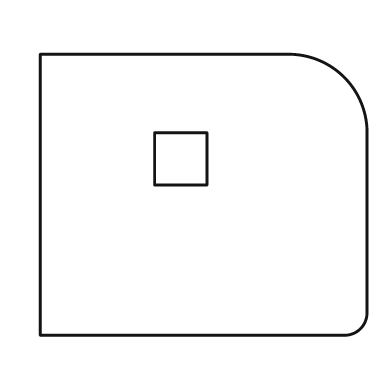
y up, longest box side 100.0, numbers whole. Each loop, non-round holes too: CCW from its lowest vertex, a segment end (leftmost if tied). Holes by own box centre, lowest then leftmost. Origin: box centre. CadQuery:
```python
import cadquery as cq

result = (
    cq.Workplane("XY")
    .moveTo(-50.0, -43.0)
    .lineTo(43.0, -43.0)
    .threePointArc((48.0, -41.0), (50.0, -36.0))
    .lineTo(50.0, 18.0)
    .threePointArc((43.0, 36.0), (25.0, 43.0))
    .lineTo(-50.0, 43.0)
    .close()
    .moveTo(-15.0, 3.0)
    .lineTo(1.0, 3.0)
    .lineTo(1.0, 19.0)
    .lineTo(-15.0, 19.0)
    .close()
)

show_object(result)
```